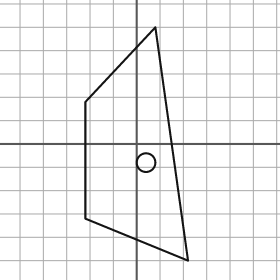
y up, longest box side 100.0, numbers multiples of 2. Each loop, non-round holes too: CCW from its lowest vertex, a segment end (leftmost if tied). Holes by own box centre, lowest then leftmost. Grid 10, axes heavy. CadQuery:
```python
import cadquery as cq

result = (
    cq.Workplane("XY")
    .moveTo(22.0, -50.0)
    .lineTo(8.0, 50.0)
    .lineTo(-22.0, 18.0)
    .lineTo(-22.0, -32.0)
    .close()
    .moveTo(4.0, -8.0)
    .circle(4.0)
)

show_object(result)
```